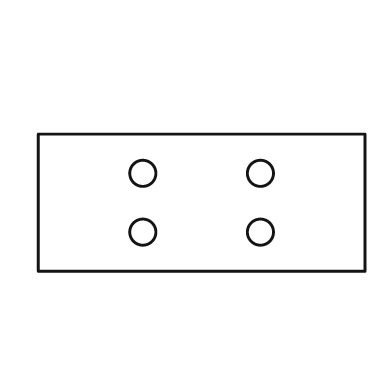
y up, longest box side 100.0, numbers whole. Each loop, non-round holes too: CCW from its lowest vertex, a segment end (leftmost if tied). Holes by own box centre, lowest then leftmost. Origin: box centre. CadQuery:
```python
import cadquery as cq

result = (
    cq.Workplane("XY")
    .moveTo(-50.0, -21.0)
    .lineTo(50.0, -21.0)
    .lineTo(50.0, 21.0)
    .lineTo(-50.0, 21.0)
    .close()
    .moveTo(-18.0, -9.0)
    .circle(4.0)
    .moveTo(18.0, -9.0)
    .circle(4.0)
    .moveTo(-18.0, 9.0)
    .circle(4.0)
    .moveTo(18.0, 9.0)
    .circle(4.0)
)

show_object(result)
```